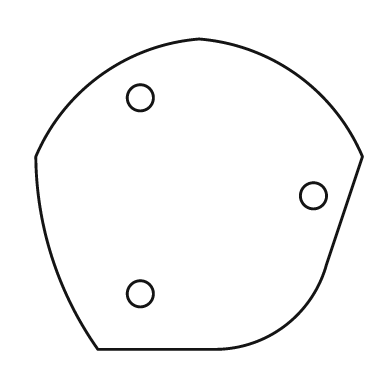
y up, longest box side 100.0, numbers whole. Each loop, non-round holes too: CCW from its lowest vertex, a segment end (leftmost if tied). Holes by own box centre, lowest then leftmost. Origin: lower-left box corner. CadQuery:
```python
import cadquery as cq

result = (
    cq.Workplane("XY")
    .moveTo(19.0, 0.0)
    .lineTo(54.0, 0.0)
    .threePointArc((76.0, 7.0), (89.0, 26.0))
    .lineTo(100.0, 59.0)
    .threePointArc((80.0, 84.0), (50.0, 95.0))
    .threePointArc((20.0, 84.0), (0.0, 59.0))
    .threePointArc((5.0, 28.0), (19.0, 0.0))
    .close()
    .moveTo(32.0, 17.0)
    .circle(4.0)
    .moveTo(85.0, 47.0)
    .circle(4.0)
    .moveTo(32.0, 77.0)
    .circle(4.0)
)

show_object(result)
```